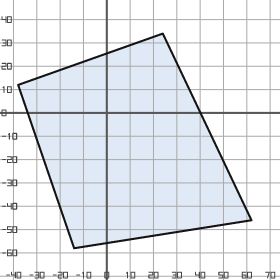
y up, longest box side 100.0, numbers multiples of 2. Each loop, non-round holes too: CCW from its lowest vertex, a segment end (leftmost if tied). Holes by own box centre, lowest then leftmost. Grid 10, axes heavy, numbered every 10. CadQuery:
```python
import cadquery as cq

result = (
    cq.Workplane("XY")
    .moveTo(-14.0, -58.0)
    .lineTo(62.0, -46.0)
    .lineTo(24.0, 34.0)
    .lineTo(-38.0, 12.0)
    .close()
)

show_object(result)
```